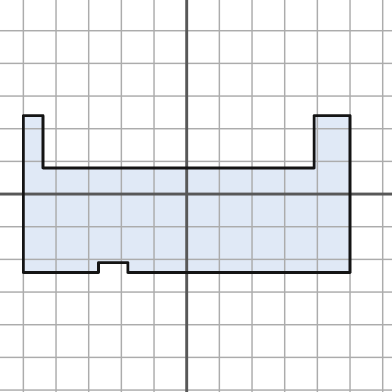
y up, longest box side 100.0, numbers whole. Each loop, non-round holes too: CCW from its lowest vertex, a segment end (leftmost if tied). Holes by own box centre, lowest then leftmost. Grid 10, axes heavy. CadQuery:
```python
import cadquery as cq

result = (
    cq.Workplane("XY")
    .moveTo(-50.0, -24.0)
    .lineTo(-27.0, -24.0)
    .lineTo(-27.0, -21.0)
    .lineTo(-18.0, -21.0)
    .lineTo(-18.0, -24.0)
    .lineTo(50.0, -24.0)
    .lineTo(50.0, 24.0)
    .lineTo(39.0, 24.0)
    .lineTo(39.0, 8.0)
    .lineTo(-44.0, 8.0)
    .lineTo(-44.0, 24.0)
    .lineTo(-50.0, 24.0)
    .close()
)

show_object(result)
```